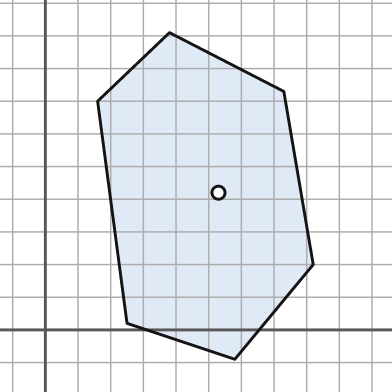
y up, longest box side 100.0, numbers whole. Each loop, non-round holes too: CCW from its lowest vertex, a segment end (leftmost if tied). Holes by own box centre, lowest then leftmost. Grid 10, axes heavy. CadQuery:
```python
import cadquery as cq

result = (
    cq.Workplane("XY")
    .moveTo(58.0, -9.0)
    .lineTo(82.0, 20.0)
    .lineTo(73.0, 73.0)
    .lineTo(38.0, 91.0)
    .lineTo(16.0, 70.0)
    .lineTo(25.0, 2.0)
    .close()
    .moveTo(53.0, 42.0)
    .circle(2.0)
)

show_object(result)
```